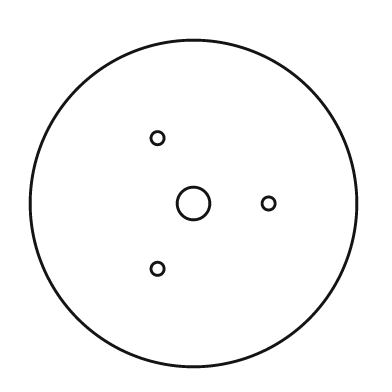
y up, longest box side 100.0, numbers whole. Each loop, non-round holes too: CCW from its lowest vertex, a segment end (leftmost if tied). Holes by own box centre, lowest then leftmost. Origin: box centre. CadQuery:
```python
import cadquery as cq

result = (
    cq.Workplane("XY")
    .moveTo(0.0, 0.0)
    .circle(50.0)
    .moveTo(-11.0, -20.0)
    .circle(2.0)
    .moveTo(0.0, 0.0)
    .circle(5.0)
    .moveTo(23.0, 0.0)
    .circle(2.0)
    .moveTo(-11.0, 20.0)
    .circle(2.0)
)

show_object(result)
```